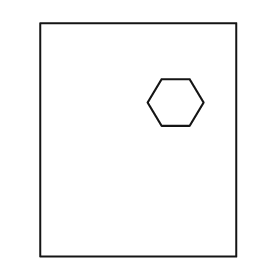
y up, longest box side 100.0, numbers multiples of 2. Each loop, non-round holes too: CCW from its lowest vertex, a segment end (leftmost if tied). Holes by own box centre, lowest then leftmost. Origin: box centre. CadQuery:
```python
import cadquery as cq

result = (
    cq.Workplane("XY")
    .moveTo(-42.0, -50.0)
    .lineTo(42.0, -50.0)
    .lineTo(42.0, 50.0)
    .lineTo(-42.0, 50.0)
    .close()
    .moveTo(10.0, 6.0)
    .lineTo(22.0, 6.0)
    .lineTo(28.0, 16.0)
    .lineTo(22.0, 26.0)
    .lineTo(10.0, 26.0)
    .lineTo(4.0, 16.0)
    .close()
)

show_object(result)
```